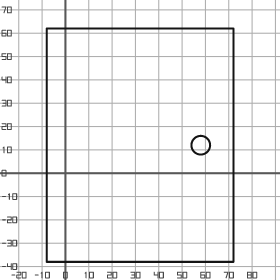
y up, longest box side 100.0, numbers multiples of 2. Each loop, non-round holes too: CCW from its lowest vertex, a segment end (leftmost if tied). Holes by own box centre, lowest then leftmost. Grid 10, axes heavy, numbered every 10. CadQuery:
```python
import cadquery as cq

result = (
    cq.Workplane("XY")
    .moveTo(-8.0, -38.0)
    .lineTo(72.0, -38.0)
    .lineTo(72.0, 62.0)
    .lineTo(-8.0, 62.0)
    .close()
    .moveTo(58.0, 12.0)
    .circle(4.0)
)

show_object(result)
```